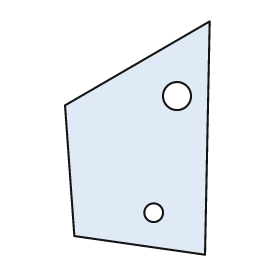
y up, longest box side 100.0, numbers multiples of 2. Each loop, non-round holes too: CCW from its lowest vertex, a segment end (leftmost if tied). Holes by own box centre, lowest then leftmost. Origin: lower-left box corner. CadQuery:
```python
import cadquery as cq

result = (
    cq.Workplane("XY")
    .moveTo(60.0, 0.0)
    .lineTo(62.0, 100.0)
    .lineTo(0.0, 64.0)
    .lineTo(4.0, 8.0)
    .close()
    .moveTo(38.0, 18.0)
    .circle(4.0)
    .moveTo(48.0, 68.0)
    .circle(6.0)
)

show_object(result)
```